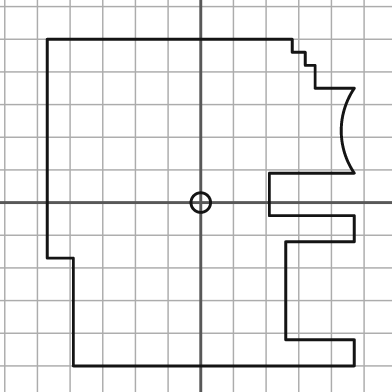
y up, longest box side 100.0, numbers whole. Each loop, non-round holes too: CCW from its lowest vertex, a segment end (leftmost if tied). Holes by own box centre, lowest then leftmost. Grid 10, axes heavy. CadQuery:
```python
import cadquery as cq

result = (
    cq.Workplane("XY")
    .moveTo(-39.0, -50.0)
    .lineTo(47.0, -50.0)
    .lineTo(47.0, -42.0)
    .lineTo(26.0, -42.0)
    .lineTo(26.0, -12.0)
    .lineTo(47.0, -12.0)
    .lineTo(47.0, -4.0)
    .lineTo(21.0, -4.0)
    .lineTo(21.0, 9.0)
    .lineTo(47.0, 9.0)
    .threePointArc((43.0, 22.0), (47.0, 35.0))
    .lineTo(35.0, 35.0)
    .lineTo(35.0, 42.0)
    .lineTo(32.0, 42.0)
    .lineTo(32.0, 46.0)
    .lineTo(28.0, 46.0)
    .lineTo(28.0, 50.0)
    .lineTo(-47.0, 50.0)
    .lineTo(-47.0, -17.0)
    .lineTo(-39.0, -17.0)
    .close()
    .moveTo(0.0, 0.0)
    .circle(3.0)
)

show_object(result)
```